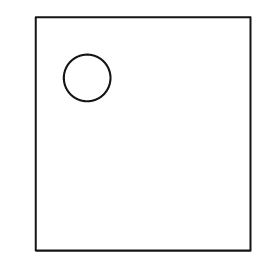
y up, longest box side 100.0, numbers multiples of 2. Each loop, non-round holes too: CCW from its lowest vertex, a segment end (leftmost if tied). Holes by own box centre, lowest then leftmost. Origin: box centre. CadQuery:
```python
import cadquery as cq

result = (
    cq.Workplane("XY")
    .moveTo(-46.0, -50.0)
    .lineTo(46.0, -50.0)
    .lineTo(46.0, 50.0)
    .lineTo(-46.0, 50.0)
    .close()
    .moveTo(-24.0, 24.0)
    .circle(10.0)
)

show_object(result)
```